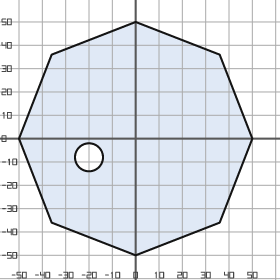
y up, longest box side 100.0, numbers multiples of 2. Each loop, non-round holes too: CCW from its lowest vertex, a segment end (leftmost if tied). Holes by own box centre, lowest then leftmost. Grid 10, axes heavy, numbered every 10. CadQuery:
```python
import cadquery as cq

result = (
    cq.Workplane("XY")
    .moveTo(0.0, -50.0)
    .lineTo(36.0, -36.0)
    .lineTo(50.0, 0.0)
    .lineTo(36.0, 36.0)
    .lineTo(0.0, 50.0)
    .lineTo(-36.0, 36.0)
    .lineTo(-50.0, 0.0)
    .lineTo(-36.0, -36.0)
    .close()
    .moveTo(-20.0, -8.0)
    .circle(6.0)
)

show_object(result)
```